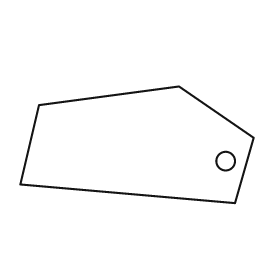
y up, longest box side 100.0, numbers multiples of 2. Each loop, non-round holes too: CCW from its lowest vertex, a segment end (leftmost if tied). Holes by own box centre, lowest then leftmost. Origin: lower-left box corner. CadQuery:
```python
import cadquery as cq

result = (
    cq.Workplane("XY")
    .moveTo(92.0, 0.0)
    .lineTo(100.0, 28.0)
    .lineTo(68.0, 50.0)
    .lineTo(8.0, 42.0)
    .lineTo(0.0, 8.0)
    .close()
    .moveTo(88.0, 18.0)
    .circle(4.0)
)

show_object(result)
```